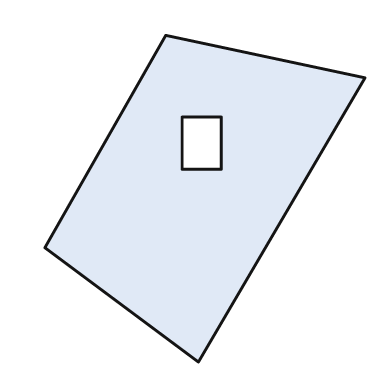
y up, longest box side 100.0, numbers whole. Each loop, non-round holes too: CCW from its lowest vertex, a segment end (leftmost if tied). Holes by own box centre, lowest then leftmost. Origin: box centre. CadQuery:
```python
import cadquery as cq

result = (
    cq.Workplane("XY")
    .moveTo(-2.0, -50.0)
    .lineTo(49.0, 37.0)
    .lineTo(-12.0, 50.0)
    .lineTo(-49.0, -15.0)
    .close()
    .moveTo(-7.0, 9.0)
    .lineTo(5.0, 9.0)
    .lineTo(5.0, 25.0)
    .lineTo(-7.0, 25.0)
    .close()
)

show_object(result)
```